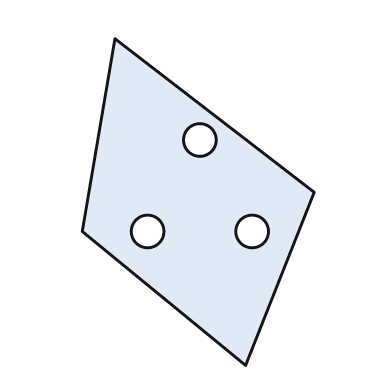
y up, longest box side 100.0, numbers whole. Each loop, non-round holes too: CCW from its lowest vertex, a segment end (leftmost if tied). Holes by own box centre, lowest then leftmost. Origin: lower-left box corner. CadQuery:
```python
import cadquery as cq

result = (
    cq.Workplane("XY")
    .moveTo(50.0, 0.0)
    .lineTo(71.0, 53.0)
    .lineTo(10.0, 100.0)
    .lineTo(0.0, 41.0)
    .close()
    .moveTo(20.0, 41.0)
    .circle(5.0)
    .moveTo(52.0, 41.0)
    .circle(5.0)
    .moveTo(36.0, 69.0)
    .circle(5.0)
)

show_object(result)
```